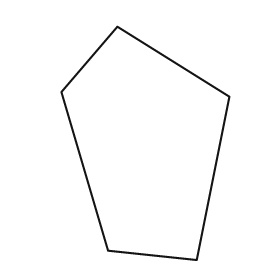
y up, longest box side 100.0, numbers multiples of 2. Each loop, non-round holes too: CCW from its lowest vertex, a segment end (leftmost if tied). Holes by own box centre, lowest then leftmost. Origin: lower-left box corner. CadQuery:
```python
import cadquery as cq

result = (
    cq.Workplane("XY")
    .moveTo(58.0, 0.0)
    .lineTo(72.0, 70.0)
    .lineTo(24.0, 100.0)
    .lineTo(0.0, 72.0)
    .lineTo(20.0, 4.0)
    .close()
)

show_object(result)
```